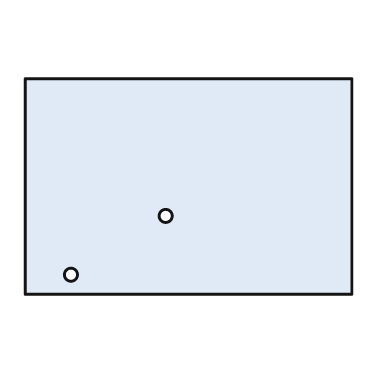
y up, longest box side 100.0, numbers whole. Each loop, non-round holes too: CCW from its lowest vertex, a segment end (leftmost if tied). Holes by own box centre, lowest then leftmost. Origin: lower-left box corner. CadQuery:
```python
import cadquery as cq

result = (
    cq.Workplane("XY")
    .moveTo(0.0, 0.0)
    .lineTo(100.0, 0.0)
    .lineTo(100.0, 66.0)
    .lineTo(0.0, 66.0)
    .close()
    .moveTo(14.0, 6.0)
    .circle(2.0)
    .moveTo(43.0, 24.0)
    .circle(2.0)
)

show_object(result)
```